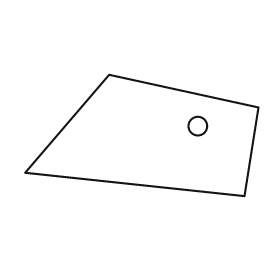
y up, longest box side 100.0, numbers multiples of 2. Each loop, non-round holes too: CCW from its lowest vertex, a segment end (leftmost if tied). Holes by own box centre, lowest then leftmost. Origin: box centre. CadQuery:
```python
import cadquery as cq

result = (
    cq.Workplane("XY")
    .moveTo(44.0, -26.0)
    .lineTo(50.0, 12.0)
    .lineTo(-14.0, 26.0)
    .lineTo(-50.0, -16.0)
    .close()
    .moveTo(24.0, 4.0)
    .circle(4.0)
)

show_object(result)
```